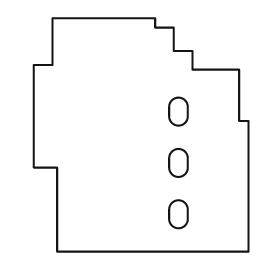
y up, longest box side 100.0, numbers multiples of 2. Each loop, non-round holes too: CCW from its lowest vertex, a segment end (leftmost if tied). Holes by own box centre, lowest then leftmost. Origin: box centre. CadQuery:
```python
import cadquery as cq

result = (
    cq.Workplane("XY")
    .moveTo(-36.0, -50.0)
    .lineTo(46.0, -50.0)
    .lineTo(46.0, 6.0)
    .lineTo(42.0, 6.0)
    .lineTo(42.0, 28.0)
    .lineTo(22.0, 28.0)
    .lineTo(22.0, 36.0)
    .lineTo(14.0, 36.0)
    .lineTo(14.0, 46.0)
    .lineTo(6.0, 46.0)
    .lineTo(6.0, 50.0)
    .lineTo(-38.0, 50.0)
    .lineTo(-38.0, 30.0)
    .lineTo(-46.0, 30.0)
    .lineTo(-46.0, -14.0)
    .lineTo(-36.0, -14.0)
    .close()
    .moveTo(12.0, -36.0)
    .threePointArc((16.0, -40.0), (20.0, -36.0))
    .lineTo(20.0, -32.0)
    .threePointArc((16.0, -28.0), (12.0, -32.0))
    .close()
    .moveTo(12.0, -14.0)
    .threePointArc((16.0, -18.0), (20.0, -14.0))
    .lineTo(20.0, -10.0)
    .threePointArc((16.0, -6.0), (12.0, -10.0))
    .close()
    .moveTo(12.0, 8.0)
    .threePointArc((16.0, 4.0), (20.0, 8.0))
    .lineTo(20.0, 12.0)
    .threePointArc((16.0, 16.0), (12.0, 12.0))
    .close()
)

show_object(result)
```